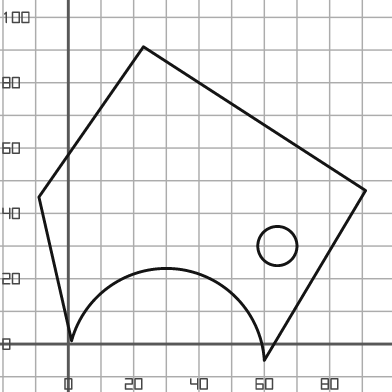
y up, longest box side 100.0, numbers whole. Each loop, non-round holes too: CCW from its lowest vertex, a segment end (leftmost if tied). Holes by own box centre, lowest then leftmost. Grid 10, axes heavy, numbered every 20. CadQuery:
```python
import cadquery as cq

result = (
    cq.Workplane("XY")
    .moveTo(60.0, -5.0)
    .lineTo(91.0, 47.0)
    .lineTo(23.0, 91.0)
    .lineTo(-9.0, 45.0)
    .lineTo(1.0, 1.0)
    .threePointArc((33.0, 23.0), (60.0, -5.0))
    .close()
    .moveTo(64.0, 30.0)
    .circle(6.0)
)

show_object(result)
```